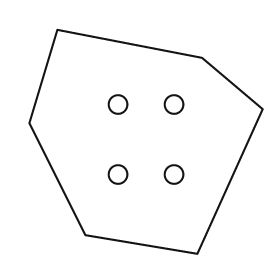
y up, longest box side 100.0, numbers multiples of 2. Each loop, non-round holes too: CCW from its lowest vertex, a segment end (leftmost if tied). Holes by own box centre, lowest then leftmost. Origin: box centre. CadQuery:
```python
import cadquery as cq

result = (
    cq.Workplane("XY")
    .moveTo(22.0, -48.0)
    .lineTo(50.0, 14.0)
    .lineTo(24.0, 36.0)
    .lineTo(-38.0, 48.0)
    .lineTo(-50.0, 8.0)
    .lineTo(-26.0, -40.0)
    .close()
    .moveTo(-12.0, -14.0)
    .circle(4.0)
    .moveTo(12.0, -14.0)
    .circle(4.0)
    .moveTo(-12.0, 16.0)
    .circle(4.0)
    .moveTo(12.0, 16.0)
    .circle(4.0)
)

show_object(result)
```